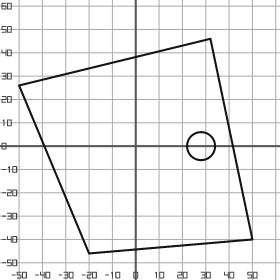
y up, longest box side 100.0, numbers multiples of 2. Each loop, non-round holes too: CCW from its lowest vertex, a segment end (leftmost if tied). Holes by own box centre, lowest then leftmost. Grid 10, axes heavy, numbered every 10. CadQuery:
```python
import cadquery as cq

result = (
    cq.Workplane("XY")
    .moveTo(-20.0, -46.0)
    .lineTo(50.0, -40.0)
    .lineTo(32.0, 46.0)
    .lineTo(-50.0, 26.0)
    .close()
    .moveTo(28.0, 0.0)
    .circle(6.0)
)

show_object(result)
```